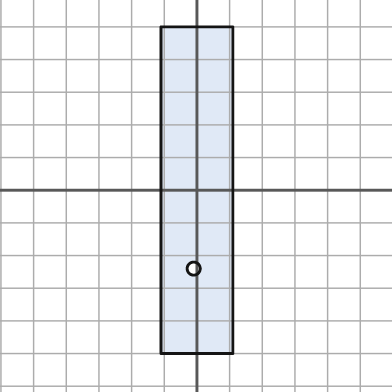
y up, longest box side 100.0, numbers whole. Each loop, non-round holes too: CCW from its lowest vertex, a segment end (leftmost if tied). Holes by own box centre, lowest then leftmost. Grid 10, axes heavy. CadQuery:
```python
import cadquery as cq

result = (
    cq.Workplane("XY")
    .moveTo(-11.0, -50.0)
    .lineTo(11.0, -50.0)
    .lineTo(11.0, 50.0)
    .lineTo(-11.0, 50.0)
    .close()
    .moveTo(-1.0, -24.0)
    .circle(2.0)
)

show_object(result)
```